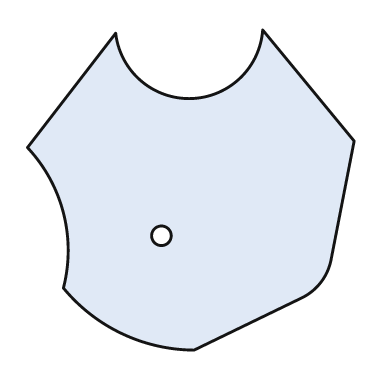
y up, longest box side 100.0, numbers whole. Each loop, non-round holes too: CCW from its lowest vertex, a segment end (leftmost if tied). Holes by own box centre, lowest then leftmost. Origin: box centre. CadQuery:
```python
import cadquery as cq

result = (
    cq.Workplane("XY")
    .moveTo(1.0, -49.0)
    .lineTo(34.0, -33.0)
    .threePointArc((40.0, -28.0), (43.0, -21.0))
    .lineTo(50.0, 15.0)
    .lineTo(22.0, 49.0)
    .threePointArc((0.0, 28.0), (-23.0, 48.0))
    .lineTo(-50.0, 13.0)
    .threePointArc((-39.0, -7.0), (-39.0, -30.0))
    .threePointArc((-21.0, -44.0), (1.0, -49.0))
    .close()
    .moveTo(-9.0, -14.0)
    .circle(3.0)
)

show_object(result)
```